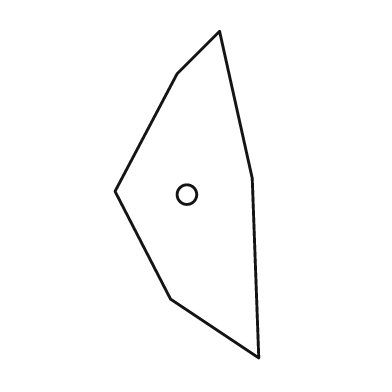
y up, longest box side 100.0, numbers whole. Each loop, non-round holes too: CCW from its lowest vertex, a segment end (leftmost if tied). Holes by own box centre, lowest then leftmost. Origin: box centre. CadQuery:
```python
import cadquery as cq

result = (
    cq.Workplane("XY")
    .moveTo(22.0, -50.0)
    .lineTo(20.0, 5.0)
    .lineTo(10.0, 50.0)
    .lineTo(-3.0, 37.0)
    .lineTo(-22.0, 1.0)
    .lineTo(-5.0, -32.0)
    .close()
    .moveTo(0.0, 0.0)
    .circle(3.0)
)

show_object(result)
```